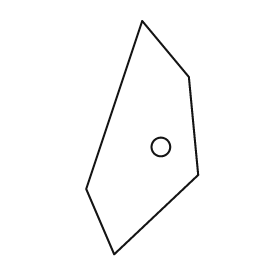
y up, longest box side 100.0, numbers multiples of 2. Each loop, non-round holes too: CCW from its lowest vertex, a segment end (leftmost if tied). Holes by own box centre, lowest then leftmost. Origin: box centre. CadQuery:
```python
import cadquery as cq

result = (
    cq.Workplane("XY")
    .moveTo(-12.0, -50.0)
    .lineTo(24.0, -16.0)
    .lineTo(20.0, 26.0)
    .lineTo(0.0, 50.0)
    .lineTo(-24.0, -22.0)
    .close()
    .moveTo(8.0, -4.0)
    .circle(4.0)
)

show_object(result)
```